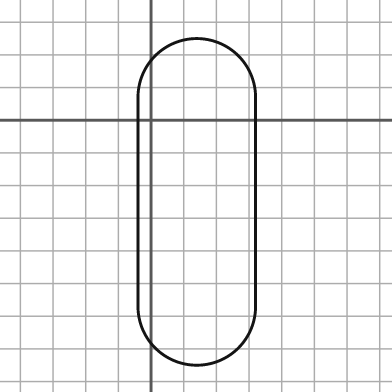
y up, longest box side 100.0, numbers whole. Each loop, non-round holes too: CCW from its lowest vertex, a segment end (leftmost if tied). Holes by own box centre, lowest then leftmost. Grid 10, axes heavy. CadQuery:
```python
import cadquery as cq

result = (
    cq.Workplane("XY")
    .moveTo(-4.0, -57.0)
    .threePointArc((14.0, -75.0), (32.0, -57.0))
    .lineTo(32.0, 7.0)
    .threePointArc((14.0, 25.0), (-4.0, 7.0))
    .close()
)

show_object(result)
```